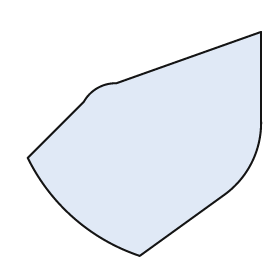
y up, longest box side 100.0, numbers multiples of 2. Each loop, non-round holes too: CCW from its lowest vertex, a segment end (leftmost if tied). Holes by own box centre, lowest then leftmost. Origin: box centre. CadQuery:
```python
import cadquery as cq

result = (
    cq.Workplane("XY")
    .moveTo(-2.0, -48.0)
    .lineTo(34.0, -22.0)
    .threePointArc((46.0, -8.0), (50.0, 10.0))
    .lineTo(50.0, 48.0)
    .lineTo(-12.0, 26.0)
    .threePointArc((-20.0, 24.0), (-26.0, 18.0))
    .lineTo(-50.0, -6.0)
    .threePointArc((-30.0, -32.0), (-2.0, -48.0))
    .close()
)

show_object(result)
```